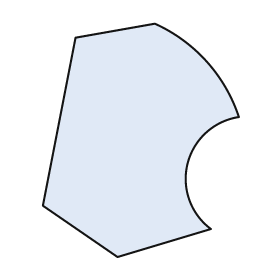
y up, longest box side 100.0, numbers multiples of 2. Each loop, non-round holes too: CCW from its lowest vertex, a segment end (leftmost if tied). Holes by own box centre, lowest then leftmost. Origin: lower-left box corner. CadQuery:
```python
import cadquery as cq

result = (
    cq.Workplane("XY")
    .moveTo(32.0, 0.0)
    .lineTo(72.0, 12.0)
    .threePointArc((62.0, 40.0), (84.0, 60.0))
    .threePointArc((70.0, 84.0), (48.0, 100.0))
    .lineTo(14.0, 94.0)
    .lineTo(0.0, 22.0)
    .close()
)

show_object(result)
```